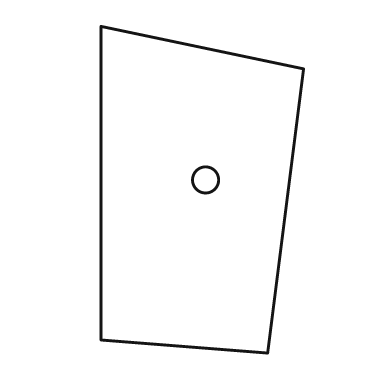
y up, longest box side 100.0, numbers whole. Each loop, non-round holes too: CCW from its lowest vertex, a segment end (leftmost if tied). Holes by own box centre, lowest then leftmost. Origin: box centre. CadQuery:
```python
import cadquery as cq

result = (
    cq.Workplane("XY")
    .moveTo(20.0, -50.0)
    .lineTo(31.0, 37.0)
    .lineTo(-31.0, 50.0)
    .lineTo(-31.0, -46.0)
    .close()
    .moveTo(1.0, 3.0)
    .circle(4.0)
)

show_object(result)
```